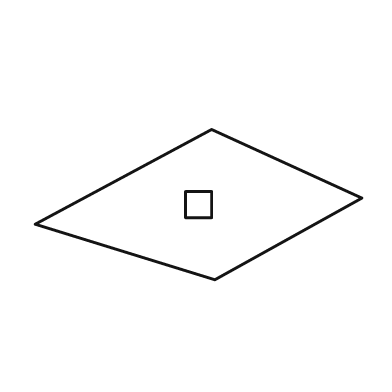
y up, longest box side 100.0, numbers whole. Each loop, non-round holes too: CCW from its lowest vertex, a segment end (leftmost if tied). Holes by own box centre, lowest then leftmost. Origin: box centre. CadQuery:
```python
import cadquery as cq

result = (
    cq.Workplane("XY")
    .moveTo(5.0, -23.0)
    .lineTo(50.0, 2.0)
    .lineTo(4.0, 23.0)
    .lineTo(-50.0, -6.0)
    .close()
    .moveTo(-4.0, -4.0)
    .lineTo(4.0, -4.0)
    .lineTo(4.0, 4.0)
    .lineTo(-4.0, 4.0)
    .close()
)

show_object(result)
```